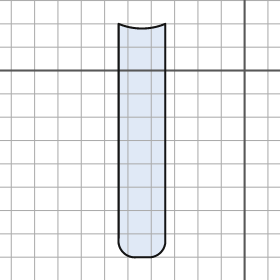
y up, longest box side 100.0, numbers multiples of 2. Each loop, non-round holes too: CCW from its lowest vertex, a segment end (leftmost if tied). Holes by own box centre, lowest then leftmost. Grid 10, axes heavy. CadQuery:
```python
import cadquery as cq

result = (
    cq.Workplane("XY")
    .moveTo(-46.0, -80.0)
    .lineTo(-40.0, -80.0)
    .threePointArc((-36.0, -78.0), (-34.0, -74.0))
    .lineTo(-34.0, 20.0)
    .threePointArc((-44.0, 18.0), (-54.0, 20.0))
    .lineTo(-54.0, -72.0)
    .threePointArc((-52.0, -78.0), (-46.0, -80.0))
    .close()
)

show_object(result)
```